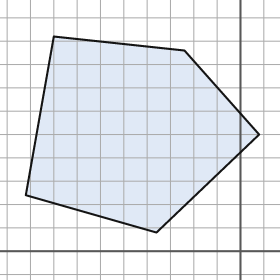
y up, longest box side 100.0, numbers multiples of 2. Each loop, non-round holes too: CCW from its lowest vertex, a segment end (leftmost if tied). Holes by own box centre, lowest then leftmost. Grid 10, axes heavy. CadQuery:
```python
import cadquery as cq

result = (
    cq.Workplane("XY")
    .moveTo(-36.0, 8.0)
    .lineTo(8.0, 50.0)
    .lineTo(-24.0, 86.0)
    .lineTo(-80.0, 92.0)
    .lineTo(-92.0, 24.0)
    .close()
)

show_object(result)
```